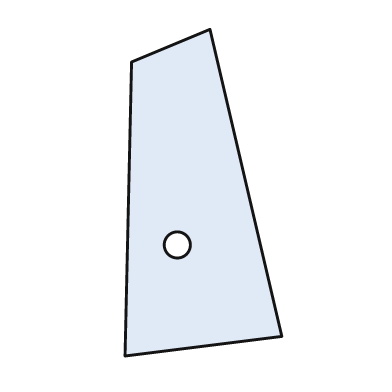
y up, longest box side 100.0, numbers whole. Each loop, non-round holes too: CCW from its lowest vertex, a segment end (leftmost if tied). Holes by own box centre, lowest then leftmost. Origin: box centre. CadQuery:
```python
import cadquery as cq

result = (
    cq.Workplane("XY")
    .moveTo(-24.0, -50.0)
    .lineTo(24.0, -44.0)
    .lineTo(2.0, 50.0)
    .lineTo(-22.0, 40.0)
    .close()
    .moveTo(-8.0, -16.0)
    .circle(4.0)
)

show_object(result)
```